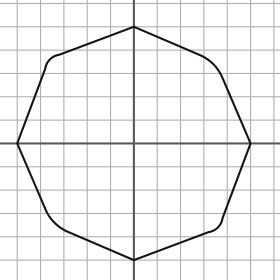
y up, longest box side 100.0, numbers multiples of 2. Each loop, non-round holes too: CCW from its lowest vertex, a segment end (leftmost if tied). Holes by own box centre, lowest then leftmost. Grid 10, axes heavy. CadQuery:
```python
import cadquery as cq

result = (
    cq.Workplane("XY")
    .moveTo(0.0, -50.0)
    .lineTo(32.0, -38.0)
    .threePointArc((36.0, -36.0), (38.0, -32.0))
    .lineTo(50.0, 0.0)
    .lineTo(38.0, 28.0)
    .threePointArc((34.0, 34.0), (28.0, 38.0))
    .lineTo(0.0, 50.0)
    .lineTo(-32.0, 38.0)
    .threePointArc((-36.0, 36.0), (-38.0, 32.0))
    .lineTo(-50.0, 0.0)
    .lineTo(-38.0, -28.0)
    .threePointArc((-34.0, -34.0), (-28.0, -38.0))
    .close()
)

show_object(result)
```